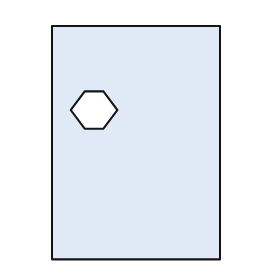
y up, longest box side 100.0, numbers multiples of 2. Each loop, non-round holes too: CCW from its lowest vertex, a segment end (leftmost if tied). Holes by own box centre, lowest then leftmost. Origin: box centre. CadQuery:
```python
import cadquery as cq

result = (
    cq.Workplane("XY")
    .moveTo(-36.0, -50.0)
    .lineTo(36.0, -50.0)
    .lineTo(36.0, 50.0)
    .lineTo(-36.0, 50.0)
    .close()
    .moveTo(-22.0, 6.0)
    .lineTo(-14.0, 6.0)
    .lineTo(-8.0, 14.0)
    .lineTo(-14.0, 22.0)
    .lineTo(-22.0, 22.0)
    .lineTo(-28.0, 14.0)
    .close()
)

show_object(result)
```